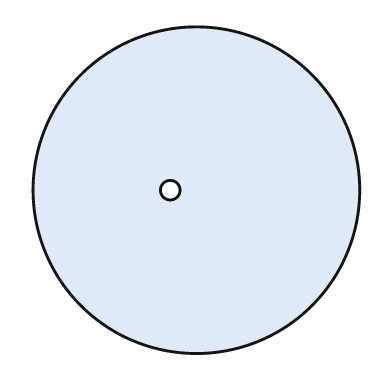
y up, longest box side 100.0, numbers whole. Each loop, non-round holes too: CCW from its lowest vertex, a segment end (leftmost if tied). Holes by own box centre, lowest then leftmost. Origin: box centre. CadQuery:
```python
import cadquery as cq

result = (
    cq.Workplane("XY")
    .moveTo(0.0, 0.0)
    .circle(50.0)
    .moveTo(-8.0, 0.0)
    .circle(3.0)
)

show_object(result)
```